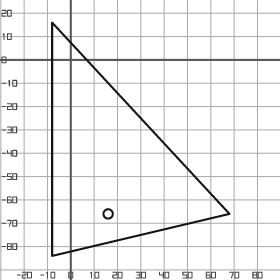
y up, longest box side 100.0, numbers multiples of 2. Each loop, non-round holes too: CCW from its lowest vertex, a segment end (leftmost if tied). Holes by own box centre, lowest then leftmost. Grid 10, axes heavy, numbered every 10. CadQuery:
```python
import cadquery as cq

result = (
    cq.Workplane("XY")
    .moveTo(-8.0, -84.0)
    .lineTo(68.0, -66.0)
    .lineTo(-8.0, 16.0)
    .close()
    .moveTo(16.0, -66.0)
    .circle(2.0)
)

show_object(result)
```